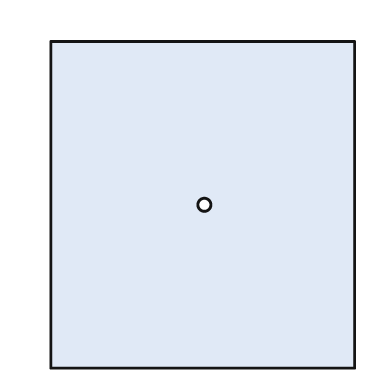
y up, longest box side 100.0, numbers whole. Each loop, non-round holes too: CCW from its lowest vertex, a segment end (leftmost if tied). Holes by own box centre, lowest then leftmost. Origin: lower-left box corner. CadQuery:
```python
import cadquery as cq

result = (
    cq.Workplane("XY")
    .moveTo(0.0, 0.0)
    .lineTo(93.0, 0.0)
    .lineTo(93.0, 100.0)
    .lineTo(0.0, 100.0)
    .close()
    .moveTo(47.0, 50.0)
    .circle(2.0)
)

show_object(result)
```